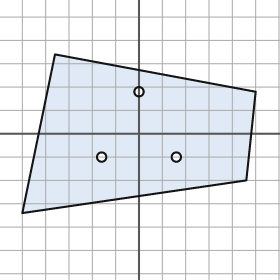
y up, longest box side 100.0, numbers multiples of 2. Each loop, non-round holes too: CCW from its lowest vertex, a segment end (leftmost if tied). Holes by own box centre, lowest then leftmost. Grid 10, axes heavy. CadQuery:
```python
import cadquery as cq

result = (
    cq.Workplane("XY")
    .moveTo(-50.0, -34.0)
    .lineTo(46.0, -20.0)
    .lineTo(50.0, 18.0)
    .lineTo(-36.0, 34.0)
    .close()
    .moveTo(-16.0, -10.0)
    .circle(2.0)
    .moveTo(16.0, -10.0)
    .circle(2.0)
    .moveTo(0.0, 18.0)
    .circle(2.0)
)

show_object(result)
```